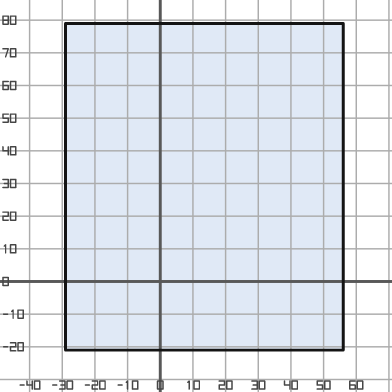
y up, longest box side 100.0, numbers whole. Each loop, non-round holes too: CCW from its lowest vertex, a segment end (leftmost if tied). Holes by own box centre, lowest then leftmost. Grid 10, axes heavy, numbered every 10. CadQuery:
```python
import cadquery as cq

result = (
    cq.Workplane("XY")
    .moveTo(-29.0, -21.0)
    .lineTo(56.0, -21.0)
    .lineTo(56.0, 79.0)
    .lineTo(-29.0, 79.0)
    .close()
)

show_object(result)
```